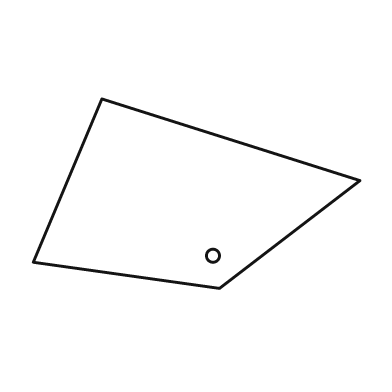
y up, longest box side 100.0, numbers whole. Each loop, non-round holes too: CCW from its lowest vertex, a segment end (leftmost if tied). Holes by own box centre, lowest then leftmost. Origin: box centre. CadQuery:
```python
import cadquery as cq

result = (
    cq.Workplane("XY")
    .moveTo(7.0, -29.0)
    .lineTo(50.0, 4.0)
    .lineTo(-29.0, 29.0)
    .lineTo(-50.0, -21.0)
    .close()
    .moveTo(5.0, -19.0)
    .circle(2.0)
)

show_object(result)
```